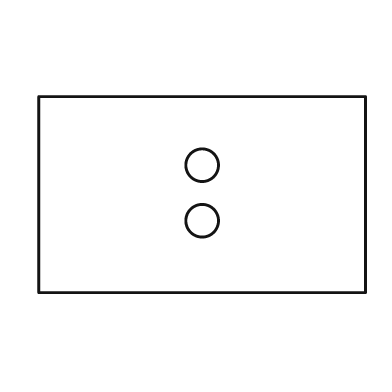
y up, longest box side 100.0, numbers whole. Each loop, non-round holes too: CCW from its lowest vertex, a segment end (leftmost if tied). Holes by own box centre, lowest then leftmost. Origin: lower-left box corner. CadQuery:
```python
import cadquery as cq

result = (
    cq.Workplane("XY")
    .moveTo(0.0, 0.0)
    .lineTo(100.0, 0.0)
    .lineTo(100.0, 60.0)
    .lineTo(0.0, 60.0)
    .close()
    .moveTo(50.0, 22.0)
    .circle(5.0)
    .moveTo(50.0, 39.0)
    .circle(5.0)
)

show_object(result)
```